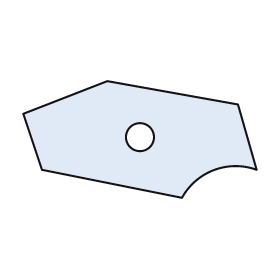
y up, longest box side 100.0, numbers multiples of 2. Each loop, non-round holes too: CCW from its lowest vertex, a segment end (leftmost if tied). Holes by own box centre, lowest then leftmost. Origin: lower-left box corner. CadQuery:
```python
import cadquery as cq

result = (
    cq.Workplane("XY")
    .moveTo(68.0, 0.0)
    .threePointArc((82.0, 12.0), (100.0, 12.0))
    .lineTo(92.0, 40.0)
    .lineTo(36.0, 50.0)
    .lineTo(0.0, 36.0)
    .lineTo(8.0, 12.0)
    .close()
    .moveTo(50.0, 26.0)
    .circle(6.0)
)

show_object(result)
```